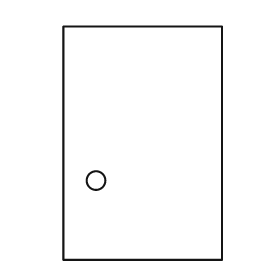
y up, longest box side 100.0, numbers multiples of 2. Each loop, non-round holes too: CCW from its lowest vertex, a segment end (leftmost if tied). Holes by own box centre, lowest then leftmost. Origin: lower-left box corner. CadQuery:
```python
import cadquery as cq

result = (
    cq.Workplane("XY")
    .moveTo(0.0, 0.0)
    .lineTo(68.0, 0.0)
    .lineTo(68.0, 100.0)
    .lineTo(0.0, 100.0)
    .close()
    .moveTo(14.0, 34.0)
    .circle(4.0)
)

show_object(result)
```